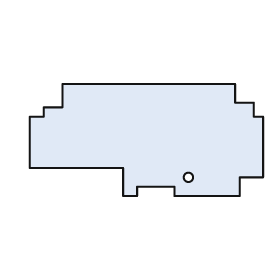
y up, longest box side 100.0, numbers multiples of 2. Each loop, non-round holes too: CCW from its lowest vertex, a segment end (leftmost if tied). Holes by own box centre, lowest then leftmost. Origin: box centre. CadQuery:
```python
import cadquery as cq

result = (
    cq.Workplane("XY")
    .moveTo(-10.0, -24.0)
    .lineTo(-4.0, -24.0)
    .lineTo(-4.0, -20.0)
    .lineTo(12.0, -20.0)
    .lineTo(12.0, -24.0)
    .lineTo(40.0, -24.0)
    .lineTo(40.0, -16.0)
    .lineTo(50.0, -16.0)
    .lineTo(50.0, 10.0)
    .lineTo(46.0, 10.0)
    .lineTo(46.0, 16.0)
    .lineTo(38.0, 16.0)
    .lineTo(38.0, 24.0)
    .lineTo(-36.0, 24.0)
    .lineTo(-36.0, 14.0)
    .lineTo(-44.0, 14.0)
    .lineTo(-44.0, 10.0)
    .lineTo(-50.0, 10.0)
    .lineTo(-50.0, -12.0)
    .lineTo(-10.0, -12.0)
    .close()
    .moveTo(18.0, -16.0)
    .circle(2.0)
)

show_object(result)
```